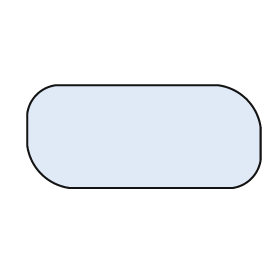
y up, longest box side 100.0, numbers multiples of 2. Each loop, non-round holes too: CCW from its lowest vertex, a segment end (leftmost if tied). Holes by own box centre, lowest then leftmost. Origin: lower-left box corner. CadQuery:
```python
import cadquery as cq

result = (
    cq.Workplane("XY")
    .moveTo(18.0, 0.0)
    .lineTo(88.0, 0.0)
    .threePointArc((96.0, 4.0), (100.0, 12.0))
    .lineTo(100.0, 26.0)
    .threePointArc((94.0, 38.0), (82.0, 44.0))
    .lineTo(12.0, 44.0)
    .threePointArc((4.0, 40.0), (0.0, 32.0))
    .lineTo(0.0, 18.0)
    .threePointArc((6.0, 6.0), (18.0, 0.0))
    .close()
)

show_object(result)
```